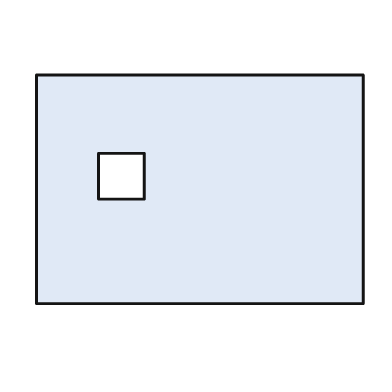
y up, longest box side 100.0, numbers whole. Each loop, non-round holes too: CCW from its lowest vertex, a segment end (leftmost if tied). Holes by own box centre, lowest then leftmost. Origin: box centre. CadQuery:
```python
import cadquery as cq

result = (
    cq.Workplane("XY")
    .moveTo(-50.0, -35.0)
    .lineTo(50.0, -35.0)
    .lineTo(50.0, 35.0)
    .lineTo(-50.0, 35.0)
    .close()
    .moveTo(-31.0, -3.0)
    .lineTo(-17.0, -3.0)
    .lineTo(-17.0, 11.0)
    .lineTo(-31.0, 11.0)
    .close()
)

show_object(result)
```